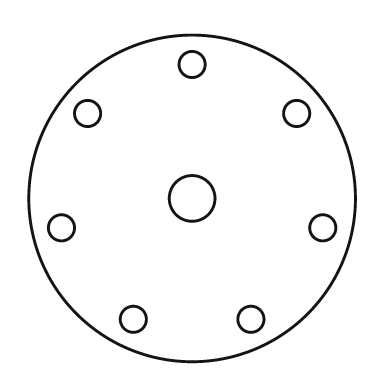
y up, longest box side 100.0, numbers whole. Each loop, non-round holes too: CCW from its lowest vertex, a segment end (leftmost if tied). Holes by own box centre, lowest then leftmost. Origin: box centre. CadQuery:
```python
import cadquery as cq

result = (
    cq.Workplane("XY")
    .moveTo(0.0, 0.0)
    .circle(50.0)
    .moveTo(-18.0, -37.0)
    .circle(4.0)
    .moveTo(18.0, -37.0)
    .circle(4.0)
    .moveTo(-40.0, -9.0)
    .circle(4.0)
    .moveTo(40.0, -9.0)
    .circle(4.0)
    .moveTo(0.0, 0.0)
    .circle(7.0)
    .moveTo(-32.0, 26.0)
    .circle(4.0)
    .moveTo(32.0, 26.0)
    .circle(4.0)
    .moveTo(0.0, 41.0)
    .circle(4.0)
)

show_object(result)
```